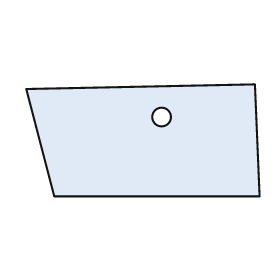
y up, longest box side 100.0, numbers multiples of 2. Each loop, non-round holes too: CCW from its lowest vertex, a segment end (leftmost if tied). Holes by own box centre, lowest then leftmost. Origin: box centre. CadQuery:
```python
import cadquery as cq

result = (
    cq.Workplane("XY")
    .moveTo(-38.0, -24.0)
    .lineTo(50.0, -24.0)
    .lineTo(48.0, 24.0)
    .lineTo(-50.0, 22.0)
    .close()
    .moveTo(8.0, 10.0)
    .circle(4.0)
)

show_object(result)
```